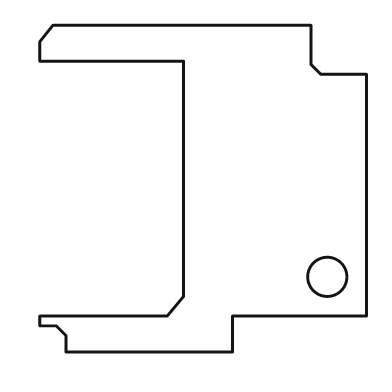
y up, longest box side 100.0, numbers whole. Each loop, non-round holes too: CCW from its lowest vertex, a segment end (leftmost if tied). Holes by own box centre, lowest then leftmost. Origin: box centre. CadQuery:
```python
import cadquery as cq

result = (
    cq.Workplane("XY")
    .moveTo(-42.0, -50.0)
    .lineTo(9.0, -50.0)
    .lineTo(9.0, -39.0)
    .lineTo(50.0, -39.0)
    .lineTo(50.0, 35.0)
    .lineTo(36.0, 35.0)
    .lineTo(33.0, 38.0)
    .lineTo(33.0, 50.0)
    .lineTo(-46.0, 50.0)
    .lineTo(-50.0, 45.0)
    .lineTo(-50.0, 39.0)
    .lineTo(-6.0, 39.0)
    .lineTo(-6.0, -33.0)
    .lineTo(-11.0, -39.0)
    .lineTo(-50.0, -39.0)
    .lineTo(-50.0, -42.0)
    .lineTo(-45.0, -42.0)
    .lineTo(-42.0, -45.0)
    .close()
    .moveTo(38.0, -27.0)
    .circle(6.0)
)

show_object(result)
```